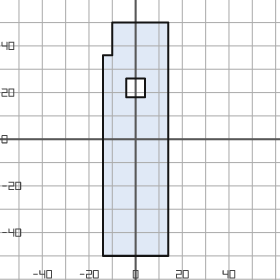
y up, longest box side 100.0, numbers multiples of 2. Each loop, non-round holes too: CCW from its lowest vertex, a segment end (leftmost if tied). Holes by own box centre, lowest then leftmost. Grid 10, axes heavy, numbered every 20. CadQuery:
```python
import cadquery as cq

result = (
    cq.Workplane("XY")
    .moveTo(-14.0, -50.0)
    .lineTo(14.0, -50.0)
    .lineTo(14.0, 50.0)
    .lineTo(-10.0, 50.0)
    .lineTo(-10.0, 36.0)
    .lineTo(-14.0, 36.0)
    .close()
    .moveTo(-4.0, 18.0)
    .lineTo(4.0, 18.0)
    .lineTo(4.0, 26.0)
    .lineTo(-4.0, 26.0)
    .close()
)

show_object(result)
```